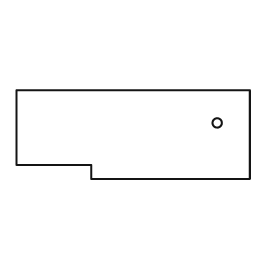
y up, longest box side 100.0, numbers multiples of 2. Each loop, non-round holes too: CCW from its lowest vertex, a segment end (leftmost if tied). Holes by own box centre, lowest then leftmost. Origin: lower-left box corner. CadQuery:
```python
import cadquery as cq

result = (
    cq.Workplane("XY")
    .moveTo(32.0, 0.0)
    .lineTo(100.0, 0.0)
    .lineTo(100.0, 38.0)
    .lineTo(0.0, 38.0)
    .lineTo(0.0, 6.0)
    .lineTo(32.0, 6.0)
    .close()
    .moveTo(86.0, 24.0)
    .circle(2.0)
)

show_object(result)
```